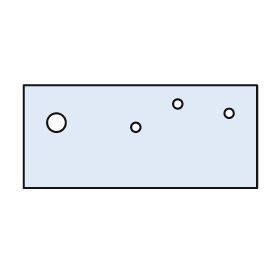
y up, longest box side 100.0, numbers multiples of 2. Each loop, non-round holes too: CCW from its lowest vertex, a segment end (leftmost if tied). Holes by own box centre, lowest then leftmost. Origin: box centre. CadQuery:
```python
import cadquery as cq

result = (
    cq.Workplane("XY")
    .moveTo(-50.0, -22.0)
    .lineTo(50.0, -22.0)
    .lineTo(50.0, 22.0)
    .lineTo(-50.0, 22.0)
    .close()
    .moveTo(-2.0, 4.0)
    .circle(2.0)
    .moveTo(-36.0, 6.0)
    .circle(4.0)
    .moveTo(38.0, 10.0)
    .circle(2.0)
    .moveTo(16.0, 14.0)
    .circle(2.0)
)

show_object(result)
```